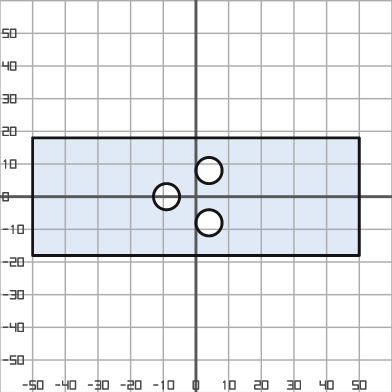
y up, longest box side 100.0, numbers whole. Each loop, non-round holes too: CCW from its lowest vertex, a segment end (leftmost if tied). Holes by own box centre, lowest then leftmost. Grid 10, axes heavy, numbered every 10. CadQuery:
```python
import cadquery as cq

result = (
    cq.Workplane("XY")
    .moveTo(-50.0, -18.0)
    .lineTo(50.0, -18.0)
    .lineTo(50.0, 18.0)
    .lineTo(-50.0, 18.0)
    .close()
    .moveTo(4.0, -8.0)
    .circle(4.0)
    .moveTo(-9.0, 0.0)
    .circle(4.0)
    .moveTo(4.0, 8.0)
    .circle(4.0)
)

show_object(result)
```